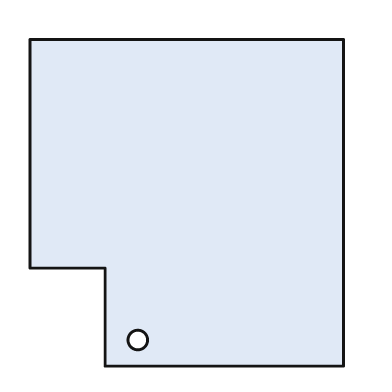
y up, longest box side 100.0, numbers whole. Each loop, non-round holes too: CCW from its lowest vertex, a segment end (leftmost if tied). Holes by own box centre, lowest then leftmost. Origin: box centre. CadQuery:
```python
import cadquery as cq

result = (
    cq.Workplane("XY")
    .moveTo(-25.0, -50.0)
    .lineTo(48.0, -50.0)
    .lineTo(48.0, 50.0)
    .lineTo(-48.0, 50.0)
    .lineTo(-48.0, -20.0)
    .lineTo(-25.0, -20.0)
    .close()
    .moveTo(-15.0, -42.0)
    .circle(3.0)
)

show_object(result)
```